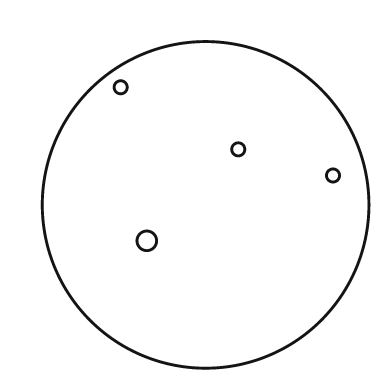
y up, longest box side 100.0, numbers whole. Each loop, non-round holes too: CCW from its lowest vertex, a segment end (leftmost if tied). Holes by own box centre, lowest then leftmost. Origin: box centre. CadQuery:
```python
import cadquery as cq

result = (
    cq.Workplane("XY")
    .moveTo(0.0, 0.0)
    .circle(50.0)
    .moveTo(-18.0, -11.0)
    .circle(3.0)
    .moveTo(39.0, 9.0)
    .circle(2.0)
    .moveTo(10.0, 17.0)
    .circle(2.0)
    .moveTo(-26.0, 36.0)
    .circle(2.0)
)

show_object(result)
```